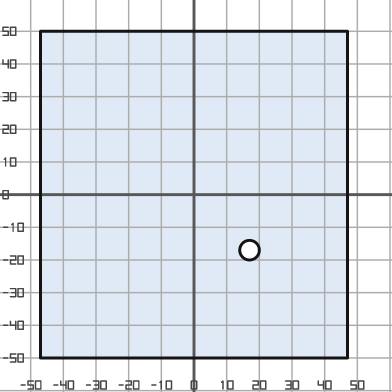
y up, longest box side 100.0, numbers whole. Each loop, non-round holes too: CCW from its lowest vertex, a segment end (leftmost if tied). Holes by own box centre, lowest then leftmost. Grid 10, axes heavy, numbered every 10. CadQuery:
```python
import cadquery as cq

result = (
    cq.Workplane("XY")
    .moveTo(-47.0, -50.0)
    .lineTo(47.0, -50.0)
    .lineTo(47.0, 50.0)
    .lineTo(-47.0, 50.0)
    .close()
    .moveTo(17.0, -17.0)
    .circle(3.0)
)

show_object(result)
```